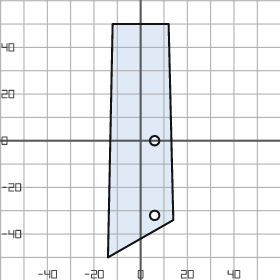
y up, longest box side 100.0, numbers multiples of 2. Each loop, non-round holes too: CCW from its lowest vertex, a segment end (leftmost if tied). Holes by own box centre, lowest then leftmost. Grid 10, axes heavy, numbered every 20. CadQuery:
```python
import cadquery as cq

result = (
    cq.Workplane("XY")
    .moveTo(-14.0, -50.0)
    .lineTo(14.0, -34.0)
    .lineTo(12.0, 50.0)
    .lineTo(-12.0, 50.0)
    .close()
    .moveTo(6.0, -32.0)
    .circle(2.0)
    .moveTo(6.0, 0.0)
    .circle(2.0)
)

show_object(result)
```